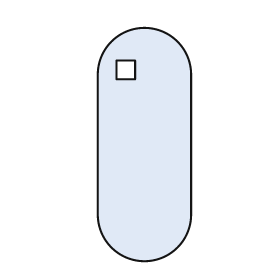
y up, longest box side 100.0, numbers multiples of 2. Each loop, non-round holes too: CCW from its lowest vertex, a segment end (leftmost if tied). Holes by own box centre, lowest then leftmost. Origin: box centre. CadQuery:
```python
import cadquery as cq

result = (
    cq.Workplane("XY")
    .moveTo(-20.0, -30.0)
    .threePointArc((0.0, -50.0), (20.0, -30.0))
    .lineTo(20.0, 30.0)
    .threePointArc((0.0, 50.0), (-20.0, 30.0))
    .close()
    .moveTo(-12.0, 28.0)
    .lineTo(-4.0, 28.0)
    .lineTo(-4.0, 36.0)
    .lineTo(-12.0, 36.0)
    .close()
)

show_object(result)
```